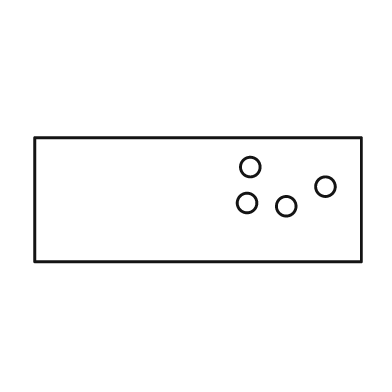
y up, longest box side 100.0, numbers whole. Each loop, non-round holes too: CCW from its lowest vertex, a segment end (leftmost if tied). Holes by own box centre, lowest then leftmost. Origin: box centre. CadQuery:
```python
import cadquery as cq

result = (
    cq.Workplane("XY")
    .moveTo(-50.0, -19.0)
    .lineTo(50.0, -19.0)
    .lineTo(50.0, 19.0)
    .lineTo(-50.0, 19.0)
    .close()
    .moveTo(27.0, -2.0)
    .circle(3.0)
    .moveTo(15.0, -1.0)
    .circle(3.0)
    .moveTo(39.0, 4.0)
    .circle(3.0)
    .moveTo(16.0, 10.0)
    .circle(3.0)
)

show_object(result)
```